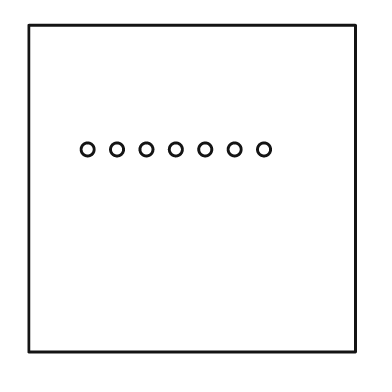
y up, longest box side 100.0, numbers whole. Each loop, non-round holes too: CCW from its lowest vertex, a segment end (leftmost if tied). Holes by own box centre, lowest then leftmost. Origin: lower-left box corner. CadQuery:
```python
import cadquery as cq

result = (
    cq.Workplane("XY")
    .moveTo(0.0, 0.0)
    .lineTo(100.0, 0.0)
    .lineTo(100.0, 100.0)
    .lineTo(0.0, 100.0)
    .close()
    .moveTo(18.0, 62.0)
    .circle(2.0)
    .moveTo(27.0, 62.0)
    .circle(2.0)
    .moveTo(36.0, 62.0)
    .circle(2.0)
    .moveTo(45.0, 62.0)
    .circle(2.0)
    .moveTo(54.0, 62.0)
    .circle(2.0)
    .moveTo(63.0, 62.0)
    .circle(2.0)
    .moveTo(72.0, 62.0)
    .circle(2.0)
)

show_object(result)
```